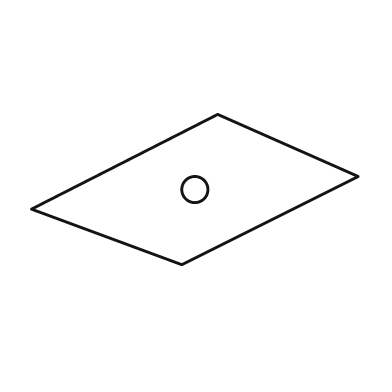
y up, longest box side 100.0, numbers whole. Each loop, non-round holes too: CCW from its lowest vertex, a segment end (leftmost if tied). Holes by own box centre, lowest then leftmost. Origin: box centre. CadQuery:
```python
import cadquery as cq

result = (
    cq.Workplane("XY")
    .moveTo(-4.0, -23.0)
    .lineTo(50.0, 4.0)
    .lineTo(7.0, 23.0)
    .lineTo(-50.0, -6.0)
    .close()
    .moveTo(0.0, 0.0)
    .circle(4.0)
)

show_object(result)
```